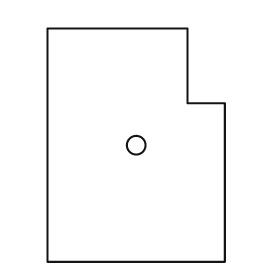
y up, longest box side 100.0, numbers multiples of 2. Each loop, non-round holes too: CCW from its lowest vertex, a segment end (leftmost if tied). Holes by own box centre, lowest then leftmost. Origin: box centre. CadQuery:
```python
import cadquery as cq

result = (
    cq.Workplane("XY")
    .moveTo(-38.0, -50.0)
    .lineTo(38.0, -50.0)
    .lineTo(38.0, 18.0)
    .lineTo(22.0, 18.0)
    .lineTo(22.0, 50.0)
    .lineTo(-38.0, 50.0)
    .close()
    .moveTo(0.0, 0.0)
    .circle(4.0)
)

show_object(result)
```